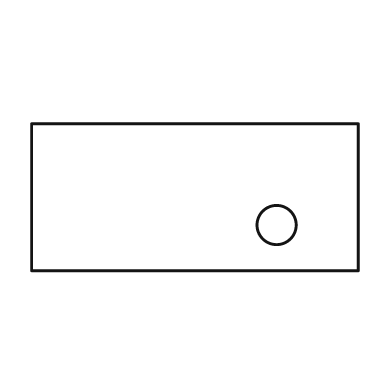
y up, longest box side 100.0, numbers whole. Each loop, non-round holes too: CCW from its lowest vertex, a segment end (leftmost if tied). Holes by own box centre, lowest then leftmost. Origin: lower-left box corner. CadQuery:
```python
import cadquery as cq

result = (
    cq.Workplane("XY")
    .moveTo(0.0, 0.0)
    .lineTo(100.0, 0.0)
    .lineTo(100.0, 45.0)
    .lineTo(0.0, 45.0)
    .close()
    .moveTo(75.0, 14.0)
    .circle(6.0)
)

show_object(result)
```